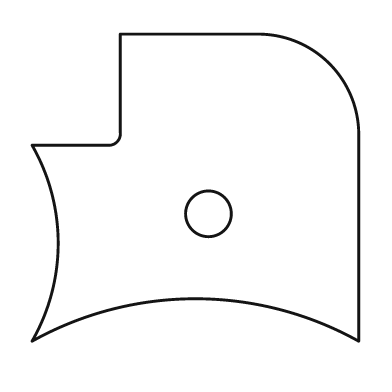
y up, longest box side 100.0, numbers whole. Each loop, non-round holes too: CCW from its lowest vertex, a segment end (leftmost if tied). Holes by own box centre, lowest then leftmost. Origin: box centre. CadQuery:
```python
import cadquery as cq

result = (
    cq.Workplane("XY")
    .moveTo(-50.0, -47.0)
    .threePointArc((0.0, -34.0), (50.0, -47.0))
    .lineTo(50.0, 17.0)
    .threePointArc((41.0, 38.0), (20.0, 47.0))
    .lineTo(-23.0, 47.0)
    .lineTo(-23.0, 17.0)
    .threePointArc((-24.0, 14.0), (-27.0, 13.0))
    .lineTo(-50.0, 13.0)
    .threePointArc((-42.0, -17.0), (-50.0, -47.0))
    .close()
    .moveTo(4.0, -8.0)
    .circle(7.0)
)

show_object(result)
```